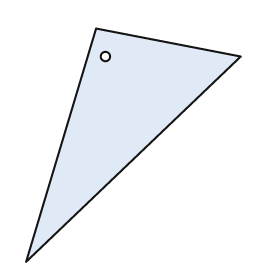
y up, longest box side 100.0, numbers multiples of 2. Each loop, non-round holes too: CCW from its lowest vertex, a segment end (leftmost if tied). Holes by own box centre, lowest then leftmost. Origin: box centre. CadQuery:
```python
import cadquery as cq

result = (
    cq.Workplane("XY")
    .moveTo(-46.0, -50.0)
    .lineTo(46.0, 38.0)
    .lineTo(-16.0, 50.0)
    .close()
    .moveTo(-12.0, 38.0)
    .circle(2.0)
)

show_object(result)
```